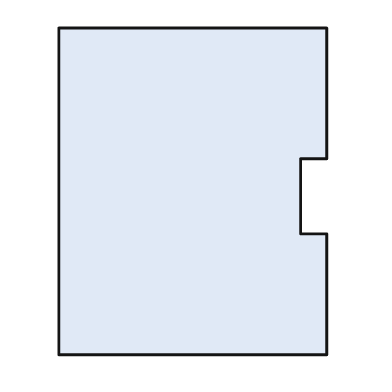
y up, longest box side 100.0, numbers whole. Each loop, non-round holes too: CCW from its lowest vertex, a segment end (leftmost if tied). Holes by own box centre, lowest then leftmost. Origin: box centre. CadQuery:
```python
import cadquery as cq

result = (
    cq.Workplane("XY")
    .moveTo(-41.0, -50.0)
    .lineTo(41.0, -50.0)
    .lineTo(41.0, -13.0)
    .lineTo(33.0, -13.0)
    .lineTo(33.0, 10.0)
    .lineTo(41.0, 10.0)
    .lineTo(41.0, 50.0)
    .lineTo(-41.0, 50.0)
    .close()
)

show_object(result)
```